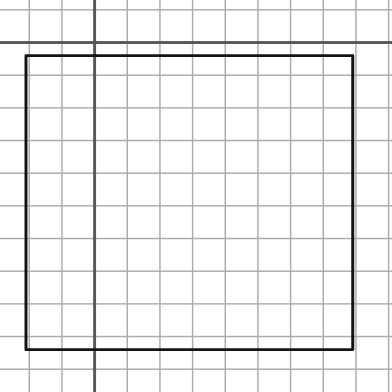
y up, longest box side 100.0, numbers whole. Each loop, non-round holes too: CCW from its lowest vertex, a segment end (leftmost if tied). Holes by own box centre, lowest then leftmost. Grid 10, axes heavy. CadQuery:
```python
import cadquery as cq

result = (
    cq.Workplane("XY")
    .moveTo(-21.0, -94.0)
    .lineTo(79.0, -94.0)
    .lineTo(79.0, -4.0)
    .lineTo(-21.0, -4.0)
    .close()
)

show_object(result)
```